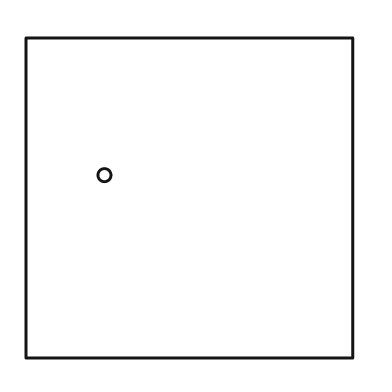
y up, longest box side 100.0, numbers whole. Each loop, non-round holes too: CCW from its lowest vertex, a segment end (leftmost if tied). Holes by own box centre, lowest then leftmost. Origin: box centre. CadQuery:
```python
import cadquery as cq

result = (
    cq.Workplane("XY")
    .moveTo(-50.0, -49.0)
    .lineTo(50.0, -49.0)
    .lineTo(50.0, 49.0)
    .lineTo(-50.0, 49.0)
    .close()
    .moveTo(-26.0, 7.0)
    .circle(2.0)
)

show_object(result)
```